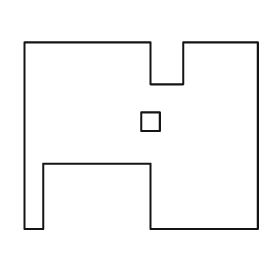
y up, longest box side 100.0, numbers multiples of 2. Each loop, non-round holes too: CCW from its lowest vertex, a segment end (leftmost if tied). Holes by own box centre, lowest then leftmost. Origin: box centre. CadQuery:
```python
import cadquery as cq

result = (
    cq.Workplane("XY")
    .moveTo(-50.0, -40.0)
    .lineTo(-42.0, -40.0)
    .lineTo(-42.0, -12.0)
    .lineTo(4.0, -12.0)
    .lineTo(4.0, -40.0)
    .lineTo(50.0, -40.0)
    .lineTo(50.0, 40.0)
    .lineTo(18.0, 40.0)
    .lineTo(18.0, 22.0)
    .lineTo(4.0, 22.0)
    .lineTo(4.0, 40.0)
    .lineTo(-50.0, 40.0)
    .close()
    .moveTo(0.0, 2.0)
    .lineTo(8.0, 2.0)
    .lineTo(8.0, 10.0)
    .lineTo(0.0, 10.0)
    .close()
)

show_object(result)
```